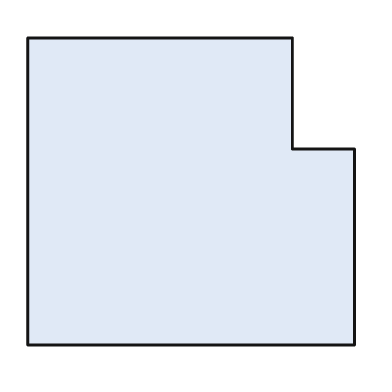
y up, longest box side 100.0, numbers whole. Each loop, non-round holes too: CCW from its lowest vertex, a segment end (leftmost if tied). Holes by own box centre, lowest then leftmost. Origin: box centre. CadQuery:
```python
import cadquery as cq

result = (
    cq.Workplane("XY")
    .moveTo(-50.0, -47.0)
    .lineTo(50.0, -47.0)
    .lineTo(50.0, 13.0)
    .lineTo(31.0, 13.0)
    .lineTo(31.0, 47.0)
    .lineTo(-50.0, 47.0)
    .close()
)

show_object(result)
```